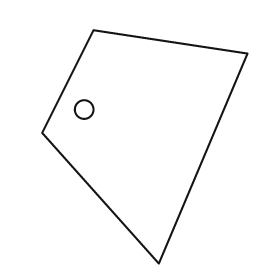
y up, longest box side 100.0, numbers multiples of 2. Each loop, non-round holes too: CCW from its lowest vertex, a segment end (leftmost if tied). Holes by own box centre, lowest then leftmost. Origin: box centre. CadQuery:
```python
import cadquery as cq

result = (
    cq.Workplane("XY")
    .moveTo(6.0, -50.0)
    .lineTo(44.0, 40.0)
    .lineTo(-22.0, 50.0)
    .lineTo(-44.0, 6.0)
    .close()
    .moveTo(-26.0, 16.0)
    .circle(4.0)
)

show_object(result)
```